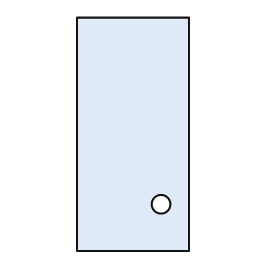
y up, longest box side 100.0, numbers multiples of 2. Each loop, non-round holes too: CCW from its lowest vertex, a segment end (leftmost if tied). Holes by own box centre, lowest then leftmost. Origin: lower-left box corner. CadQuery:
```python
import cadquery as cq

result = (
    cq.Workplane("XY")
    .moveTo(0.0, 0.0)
    .lineTo(48.0, 0.0)
    .lineTo(48.0, 100.0)
    .lineTo(0.0, 100.0)
    .close()
    .moveTo(36.0, 20.0)
    .circle(4.0)
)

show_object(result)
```